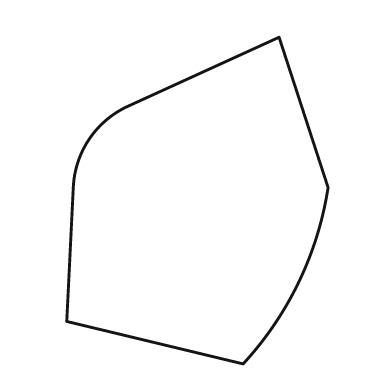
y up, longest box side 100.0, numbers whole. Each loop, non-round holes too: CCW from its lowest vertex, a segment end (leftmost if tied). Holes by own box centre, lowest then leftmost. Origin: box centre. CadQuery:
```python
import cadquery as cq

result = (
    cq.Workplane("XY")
    .moveTo(14.0, -50.0)
    .threePointArc((31.0, -25.0), (40.0, 4.0))
    .lineTo(25.0, 50.0)
    .lineTo(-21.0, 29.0)
    .threePointArc((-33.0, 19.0), (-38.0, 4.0))
    .lineTo(-40.0, -37.0)
    .close()
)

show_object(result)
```